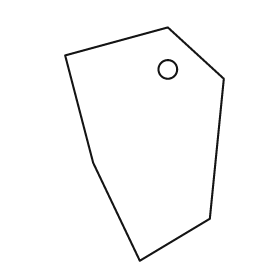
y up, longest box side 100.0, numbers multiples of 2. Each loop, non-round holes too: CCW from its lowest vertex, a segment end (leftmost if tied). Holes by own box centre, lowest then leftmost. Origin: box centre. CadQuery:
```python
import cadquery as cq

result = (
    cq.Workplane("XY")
    .moveTo(-2.0, -50.0)
    .lineTo(28.0, -32.0)
    .lineTo(34.0, 28.0)
    .lineTo(10.0, 50.0)
    .lineTo(-34.0, 38.0)
    .lineTo(-22.0, -8.0)
    .close()
    .moveTo(10.0, 32.0)
    .circle(4.0)
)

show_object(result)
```